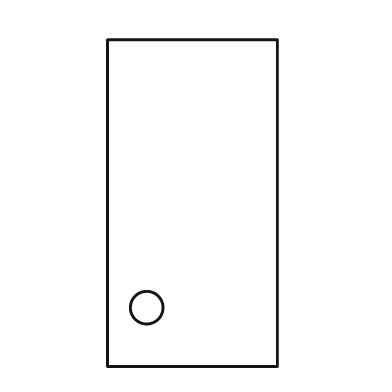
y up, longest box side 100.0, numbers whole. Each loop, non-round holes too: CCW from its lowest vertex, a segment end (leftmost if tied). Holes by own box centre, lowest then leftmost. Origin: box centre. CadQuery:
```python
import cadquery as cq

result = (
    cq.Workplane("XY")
    .moveTo(-26.0, -50.0)
    .lineTo(26.0, -50.0)
    .lineTo(26.0, 50.0)
    .lineTo(-26.0, 50.0)
    .close()
    .moveTo(-14.0, -32.0)
    .circle(5.0)
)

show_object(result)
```